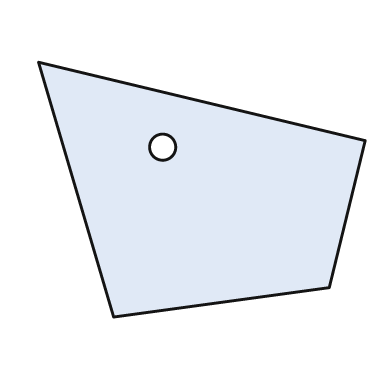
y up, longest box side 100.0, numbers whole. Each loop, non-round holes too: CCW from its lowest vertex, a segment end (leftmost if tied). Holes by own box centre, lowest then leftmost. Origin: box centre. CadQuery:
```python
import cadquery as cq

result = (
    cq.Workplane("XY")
    .moveTo(-27.0, -39.0)
    .lineTo(39.0, -30.0)
    .lineTo(50.0, 15.0)
    .lineTo(-50.0, 39.0)
    .close()
    .moveTo(-12.0, 13.0)
    .circle(4.0)
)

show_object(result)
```